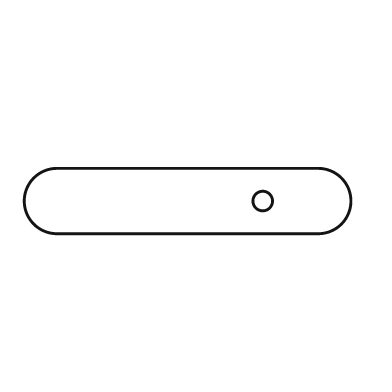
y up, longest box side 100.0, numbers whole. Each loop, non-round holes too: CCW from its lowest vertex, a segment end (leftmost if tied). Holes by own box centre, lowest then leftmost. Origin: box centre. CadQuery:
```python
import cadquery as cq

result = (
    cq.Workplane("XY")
    .moveTo(-40.0, -10.0)
    .lineTo(40.0, -10.0)
    .threePointArc((50.0, 0.0), (40.0, 10.0))
    .lineTo(-40.0, 10.0)
    .threePointArc((-50.0, 0.0), (-40.0, -10.0))
    .close()
    .moveTo(23.0, 0.0)
    .circle(3.0)
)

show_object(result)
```